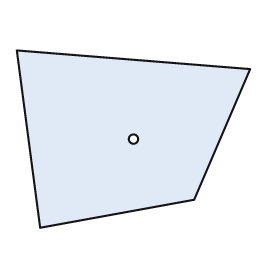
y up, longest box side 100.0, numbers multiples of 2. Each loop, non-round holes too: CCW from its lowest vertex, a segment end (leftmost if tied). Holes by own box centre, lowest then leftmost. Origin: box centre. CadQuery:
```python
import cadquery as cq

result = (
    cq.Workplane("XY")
    .moveTo(-40.0, -38.0)
    .lineTo(26.0, -26.0)
    .lineTo(50.0, 30.0)
    .lineTo(-50.0, 38.0)
    .close()
    .moveTo(0.0, 0.0)
    .circle(2.0)
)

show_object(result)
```